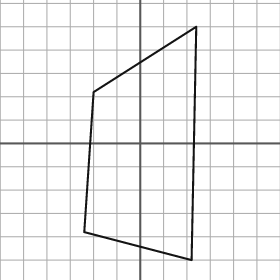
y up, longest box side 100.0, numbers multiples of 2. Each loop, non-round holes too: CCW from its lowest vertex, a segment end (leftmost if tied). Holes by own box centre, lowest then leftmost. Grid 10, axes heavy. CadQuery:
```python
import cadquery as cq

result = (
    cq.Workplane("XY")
    .moveTo(22.0, -50.0)
    .lineTo(24.0, 50.0)
    .lineTo(-20.0, 22.0)
    .lineTo(-24.0, -38.0)
    .close()
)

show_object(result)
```